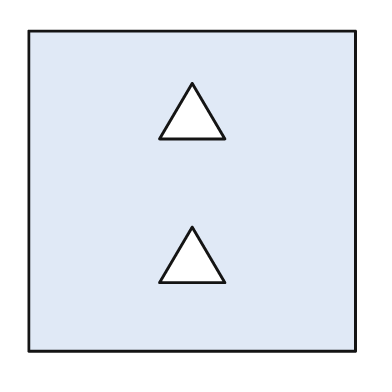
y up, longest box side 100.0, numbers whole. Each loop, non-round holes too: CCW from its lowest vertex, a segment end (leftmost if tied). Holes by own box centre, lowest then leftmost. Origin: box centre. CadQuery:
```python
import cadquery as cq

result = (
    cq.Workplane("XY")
    .moveTo(-50.0, -49.0)
    .lineTo(50.0, -49.0)
    .lineTo(50.0, 49.0)
    .lineTo(-50.0, 49.0)
    .close()
    .moveTo(-10.0, -28.0)
    .lineTo(10.0, -28.0)
    .lineTo(0.0, -11.0)
    .close()
    .moveTo(-10.0, 16.0)
    .lineTo(10.0, 16.0)
    .lineTo(0.0, 33.0)
    .close()
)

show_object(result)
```